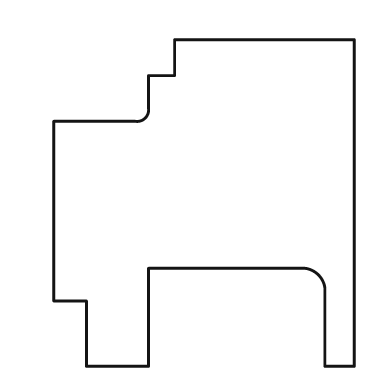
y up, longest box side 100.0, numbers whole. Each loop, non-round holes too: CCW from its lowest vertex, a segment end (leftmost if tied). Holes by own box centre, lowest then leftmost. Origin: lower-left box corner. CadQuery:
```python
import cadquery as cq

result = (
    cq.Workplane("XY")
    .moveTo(10.0, 0.0)
    .lineTo(29.0, 0.0)
    .lineTo(29.0, 30.0)
    .lineTo(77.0, 30.0)
    .threePointArc((81.0, 28.0), (83.0, 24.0))
    .lineTo(83.0, 0.0)
    .lineTo(92.0, 0.0)
    .lineTo(92.0, 100.0)
    .lineTo(37.0, 100.0)
    .lineTo(37.0, 89.0)
    .lineTo(29.0, 89.0)
    .lineTo(29.0, 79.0)
    .threePointArc((28.0, 76.0), (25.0, 75.0))
    .lineTo(0.0, 75.0)
    .lineTo(0.0, 20.0)
    .lineTo(10.0, 20.0)
    .close()
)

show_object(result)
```